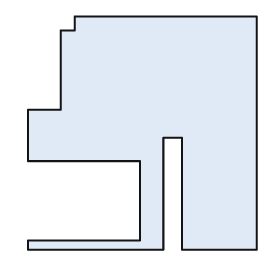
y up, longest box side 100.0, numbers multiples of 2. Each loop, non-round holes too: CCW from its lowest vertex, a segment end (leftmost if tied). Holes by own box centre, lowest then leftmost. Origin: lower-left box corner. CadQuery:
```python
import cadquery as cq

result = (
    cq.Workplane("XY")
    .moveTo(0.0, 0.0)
    .lineTo(58.0, 0.0)
    .lineTo(58.0, 48.0)
    .lineTo(66.0, 48.0)
    .lineTo(66.0, 0.0)
    .lineTo(98.0, 0.0)
    .lineTo(98.0, 100.0)
    .lineTo(20.0, 100.0)
    .lineTo(20.0, 94.0)
    .lineTo(14.0, 94.0)
    .lineTo(14.0, 60.0)
    .lineTo(0.0, 60.0)
    .lineTo(0.0, 38.0)
    .lineTo(48.0, 38.0)
    .lineTo(48.0, 4.0)
    .lineTo(0.0, 4.0)
    .close()
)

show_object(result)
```